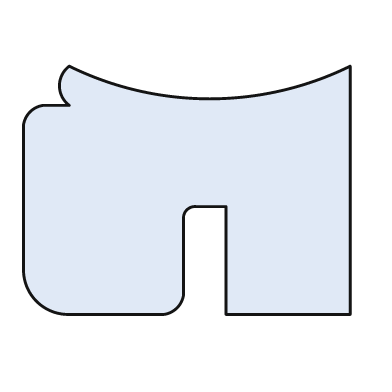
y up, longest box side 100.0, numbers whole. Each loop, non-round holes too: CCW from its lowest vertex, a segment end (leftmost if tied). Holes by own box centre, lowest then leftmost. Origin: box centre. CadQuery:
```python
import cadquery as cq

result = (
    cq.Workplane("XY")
    .moveTo(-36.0, -38.0)
    .lineTo(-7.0, -38.0)
    .threePointArc((-3.0, -36.0), (-1.0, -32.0))
    .lineTo(-1.0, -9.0)
    .threePointArc((0.0, -6.0), (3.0, -5.0))
    .lineTo(12.0, -5.0)
    .lineTo(12.0, -38.0)
    .lineTo(50.0, -38.0)
    .lineTo(50.0, 38.0)
    .threePointArc((7.0, 28.0), (-36.0, 38.0))
    .threePointArc((-39.0, 32.0), (-36.0, 26.0))
    .lineTo(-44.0, 26.0)
    .threePointArc((-48.0, 24.0), (-50.0, 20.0))
    .lineTo(-50.0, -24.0)
    .threePointArc((-46.0, -34.0), (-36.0, -38.0))
    .close()
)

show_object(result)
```